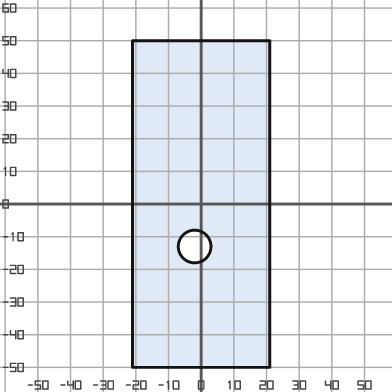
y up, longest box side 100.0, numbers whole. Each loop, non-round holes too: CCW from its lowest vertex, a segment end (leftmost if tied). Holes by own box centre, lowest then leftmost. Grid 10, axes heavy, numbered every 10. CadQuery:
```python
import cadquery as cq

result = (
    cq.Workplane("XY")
    .moveTo(-21.0, -50.0)
    .lineTo(21.0, -50.0)
    .lineTo(21.0, 50.0)
    .lineTo(-21.0, 50.0)
    .close()
    .moveTo(-2.0, -13.0)
    .circle(5.0)
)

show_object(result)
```